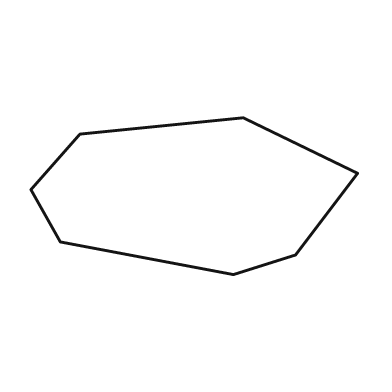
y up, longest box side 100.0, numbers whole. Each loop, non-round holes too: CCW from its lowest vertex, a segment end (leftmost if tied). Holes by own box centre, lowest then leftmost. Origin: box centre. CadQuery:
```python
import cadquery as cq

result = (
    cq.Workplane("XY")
    .moveTo(12.0, -24.0)
    .lineTo(31.0, -18.0)
    .lineTo(50.0, 7.0)
    .lineTo(15.0, 24.0)
    .lineTo(-35.0, 19.0)
    .lineTo(-50.0, 2.0)
    .lineTo(-41.0, -14.0)
    .close()
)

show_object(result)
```